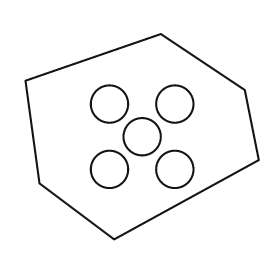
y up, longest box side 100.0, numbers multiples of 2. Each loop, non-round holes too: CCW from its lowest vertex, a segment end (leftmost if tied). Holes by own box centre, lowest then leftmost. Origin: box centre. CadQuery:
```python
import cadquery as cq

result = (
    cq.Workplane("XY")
    .moveTo(-12.0, -44.0)
    .lineTo(50.0, -10.0)
    .lineTo(44.0, 20.0)
    .lineTo(8.0, 44.0)
    .lineTo(-50.0, 24.0)
    .lineTo(-44.0, -20.0)
    .close()
    .moveTo(-14.0, -14.0)
    .circle(8.0)
    .moveTo(14.0, -14.0)
    .circle(8.0)
    .moveTo(0.0, 0.0)
    .circle(8.0)
    .moveTo(-14.0, 14.0)
    .circle(8.0)
    .moveTo(14.0, 14.0)
    .circle(8.0)
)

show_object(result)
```